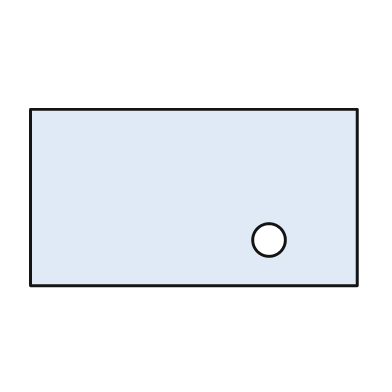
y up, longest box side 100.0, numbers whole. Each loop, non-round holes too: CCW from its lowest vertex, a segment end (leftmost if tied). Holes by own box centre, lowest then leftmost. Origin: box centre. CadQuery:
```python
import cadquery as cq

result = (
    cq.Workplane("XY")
    .moveTo(-50.0, -27.0)
    .lineTo(50.0, -27.0)
    .lineTo(50.0, 27.0)
    .lineTo(-50.0, 27.0)
    .close()
    .moveTo(23.0, -13.0)
    .circle(5.0)
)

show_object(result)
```